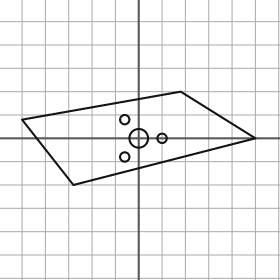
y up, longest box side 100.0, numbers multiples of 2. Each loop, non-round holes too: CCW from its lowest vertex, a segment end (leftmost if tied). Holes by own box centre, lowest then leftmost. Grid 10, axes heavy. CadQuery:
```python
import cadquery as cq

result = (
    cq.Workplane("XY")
    .moveTo(-28.0, -20.0)
    .lineTo(50.0, 0.0)
    .lineTo(18.0, 20.0)
    .lineTo(-50.0, 8.0)
    .close()
    .moveTo(-6.0, -8.0)
    .circle(2.0)
    .moveTo(0.0, 0.0)
    .circle(4.0)
    .moveTo(10.0, 0.0)
    .circle(2.0)
    .moveTo(-6.0, 8.0)
    .circle(2.0)
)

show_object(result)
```